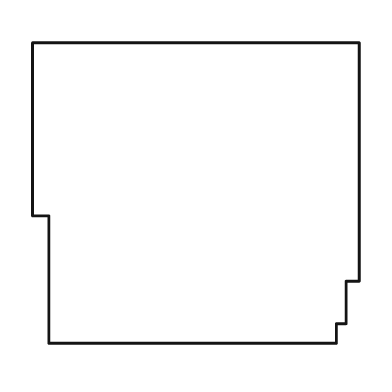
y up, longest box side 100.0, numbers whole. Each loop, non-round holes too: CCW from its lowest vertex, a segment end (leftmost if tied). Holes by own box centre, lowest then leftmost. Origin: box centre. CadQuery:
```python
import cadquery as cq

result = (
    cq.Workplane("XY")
    .moveTo(-45.0, -46.0)
    .lineTo(43.0, -46.0)
    .lineTo(43.0, -40.0)
    .lineTo(46.0, -40.0)
    .lineTo(46.0, -27.0)
    .lineTo(50.0, -27.0)
    .lineTo(50.0, 46.0)
    .lineTo(-50.0, 46.0)
    .lineTo(-50.0, -7.0)
    .lineTo(-45.0, -7.0)
    .close()
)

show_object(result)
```